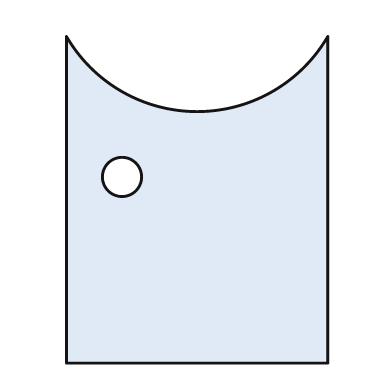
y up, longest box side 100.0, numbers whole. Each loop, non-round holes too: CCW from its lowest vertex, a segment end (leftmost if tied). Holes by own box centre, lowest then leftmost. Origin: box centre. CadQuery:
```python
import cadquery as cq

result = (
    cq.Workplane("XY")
    .moveTo(-40.0, -50.0)
    .lineTo(40.0, -50.0)
    .lineTo(40.0, 50.0)
    .threePointArc((0.0, 27.0), (-40.0, 50.0))
    .close()
    .moveTo(-23.0, 7.0)
    .circle(6.0)
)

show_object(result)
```